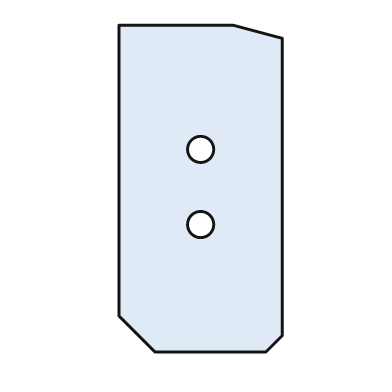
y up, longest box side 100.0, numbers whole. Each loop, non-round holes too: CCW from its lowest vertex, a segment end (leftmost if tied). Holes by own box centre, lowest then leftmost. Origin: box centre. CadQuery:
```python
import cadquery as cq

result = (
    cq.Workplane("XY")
    .moveTo(-14.0, -50.0)
    .lineTo(20.0, -50.0)
    .lineTo(25.0, -45.0)
    .lineTo(25.0, 46.0)
    .lineTo(10.0, 50.0)
    .lineTo(-25.0, 50.0)
    .lineTo(-25.0, -39.0)
    .close()
    .moveTo(0.0, -11.0)
    .circle(4.0)
    .moveTo(0.0, 12.0)
    .circle(4.0)
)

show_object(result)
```